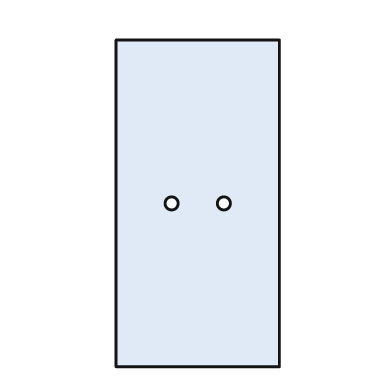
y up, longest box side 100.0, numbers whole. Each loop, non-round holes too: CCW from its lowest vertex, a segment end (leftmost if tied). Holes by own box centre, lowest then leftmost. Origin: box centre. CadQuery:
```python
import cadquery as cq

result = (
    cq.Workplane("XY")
    .moveTo(-25.0, -50.0)
    .lineTo(25.0, -50.0)
    .lineTo(25.0, 50.0)
    .lineTo(-25.0, 50.0)
    .close()
    .moveTo(-8.0, 0.0)
    .circle(2.0)
    .moveTo(8.0, 0.0)
    .circle(2.0)
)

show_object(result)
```